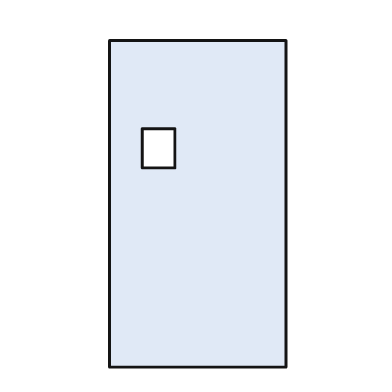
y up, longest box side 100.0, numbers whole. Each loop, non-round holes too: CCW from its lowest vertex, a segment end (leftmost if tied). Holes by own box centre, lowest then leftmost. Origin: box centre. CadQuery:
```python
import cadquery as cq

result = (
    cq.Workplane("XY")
    .moveTo(-27.0, -50.0)
    .lineTo(27.0, -50.0)
    .lineTo(27.0, 50.0)
    .lineTo(-27.0, 50.0)
    .close()
    .moveTo(-17.0, 11.0)
    .lineTo(-7.0, 11.0)
    .lineTo(-7.0, 23.0)
    .lineTo(-17.0, 23.0)
    .close()
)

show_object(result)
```